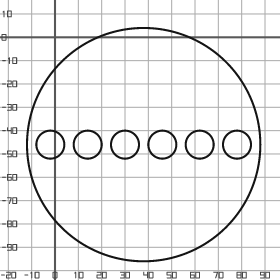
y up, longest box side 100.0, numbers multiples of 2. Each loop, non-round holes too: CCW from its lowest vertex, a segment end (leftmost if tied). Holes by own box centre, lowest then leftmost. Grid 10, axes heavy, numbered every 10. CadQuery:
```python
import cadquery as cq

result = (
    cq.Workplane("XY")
    .moveTo(38.0, -46.0)
    .circle(50.0)
    .moveTo(-2.0, -46.0)
    .circle(6.0)
    .moveTo(14.0, -46.0)
    .circle(6.0)
    .moveTo(30.0, -46.0)
    .circle(6.0)
    .moveTo(46.0, -46.0)
    .circle(6.0)
    .moveTo(62.0, -46.0)
    .circle(6.0)
    .moveTo(78.0, -46.0)
    .circle(6.0)
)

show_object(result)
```